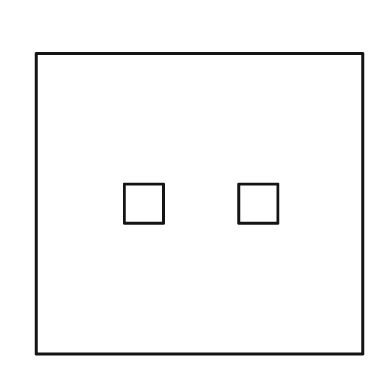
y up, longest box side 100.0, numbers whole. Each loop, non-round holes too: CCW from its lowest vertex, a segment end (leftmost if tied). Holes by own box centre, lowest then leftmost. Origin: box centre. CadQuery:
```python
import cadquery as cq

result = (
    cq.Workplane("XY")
    .moveTo(-50.0, -46.0)
    .lineTo(50.0, -46.0)
    .lineTo(50.0, 46.0)
    .lineTo(-50.0, 46.0)
    .close()
    .moveTo(-23.0, -6.0)
    .lineTo(-11.0, -6.0)
    .lineTo(-11.0, 6.0)
    .lineTo(-23.0, 6.0)
    .close()
    .moveTo(12.0, -6.0)
    .lineTo(24.0, -6.0)
    .lineTo(24.0, 6.0)
    .lineTo(12.0, 6.0)
    .close()
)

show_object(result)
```